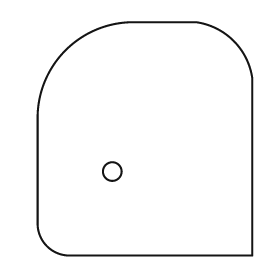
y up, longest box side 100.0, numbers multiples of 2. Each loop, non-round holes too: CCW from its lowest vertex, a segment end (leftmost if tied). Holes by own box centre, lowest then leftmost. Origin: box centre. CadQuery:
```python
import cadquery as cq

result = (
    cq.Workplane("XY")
    .moveTo(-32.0, -50.0)
    .lineTo(46.0, -50.0)
    .lineTo(46.0, 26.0)
    .threePointArc((38.0, 42.0), (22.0, 50.0))
    .lineTo(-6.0, 50.0)
    .threePointArc((-34.0, 38.0), (-46.0, 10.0))
    .lineTo(-46.0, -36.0)
    .threePointArc((-42.0, -46.0), (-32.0, -50.0))
    .close()
    .moveTo(-14.0, -14.0)
    .circle(4.0)
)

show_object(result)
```